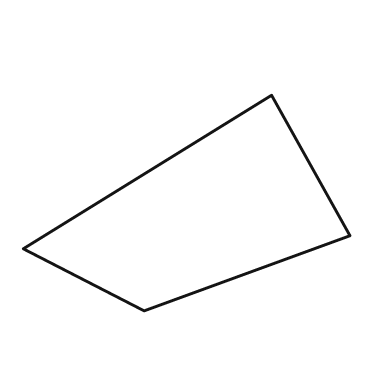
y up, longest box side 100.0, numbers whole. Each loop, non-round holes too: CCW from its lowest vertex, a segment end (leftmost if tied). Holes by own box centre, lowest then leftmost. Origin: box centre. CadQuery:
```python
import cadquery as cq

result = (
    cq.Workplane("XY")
    .moveTo(-13.0, -33.0)
    .lineTo(50.0, -10.0)
    .lineTo(26.0, 33.0)
    .lineTo(-50.0, -14.0)
    .close()
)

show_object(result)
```